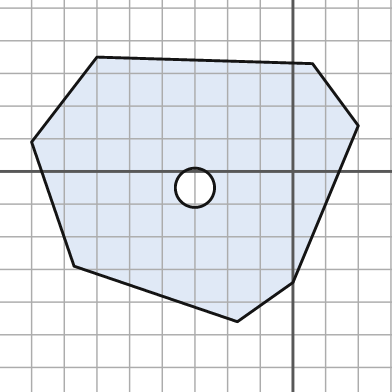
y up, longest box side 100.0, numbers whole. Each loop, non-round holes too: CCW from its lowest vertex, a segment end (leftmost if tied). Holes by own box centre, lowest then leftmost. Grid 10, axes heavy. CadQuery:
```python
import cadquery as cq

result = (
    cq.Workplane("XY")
    .moveTo(-17.0, -46.0)
    .lineTo(0.0, -34.0)
    .lineTo(20.0, 14.0)
    .lineTo(6.0, 33.0)
    .lineTo(-60.0, 35.0)
    .lineTo(-80.0, 9.0)
    .lineTo(-67.0, -29.0)
    .close()
    .moveTo(-30.0, -5.0)
    .circle(6.0)
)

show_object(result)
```